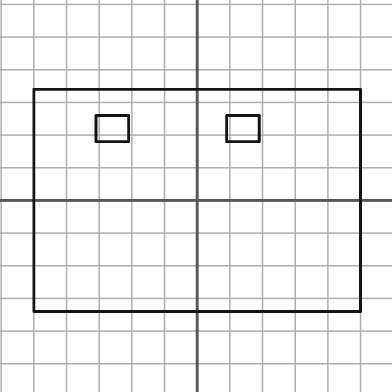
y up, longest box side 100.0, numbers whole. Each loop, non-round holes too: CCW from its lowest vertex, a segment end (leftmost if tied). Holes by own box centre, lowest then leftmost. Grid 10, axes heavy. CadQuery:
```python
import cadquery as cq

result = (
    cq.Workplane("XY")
    .moveTo(-50.0, -34.0)
    .lineTo(50.0, -34.0)
    .lineTo(50.0, 34.0)
    .lineTo(-50.0, 34.0)
    .close()
    .moveTo(-31.0, 18.0)
    .lineTo(-21.0, 18.0)
    .lineTo(-21.0, 26.0)
    .lineTo(-31.0, 26.0)
    .close()
    .moveTo(9.0, 18.0)
    .lineTo(19.0, 18.0)
    .lineTo(19.0, 26.0)
    .lineTo(9.0, 26.0)
    .close()
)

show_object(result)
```